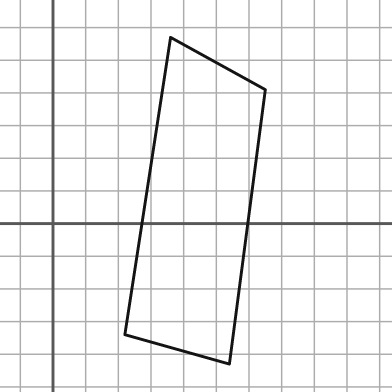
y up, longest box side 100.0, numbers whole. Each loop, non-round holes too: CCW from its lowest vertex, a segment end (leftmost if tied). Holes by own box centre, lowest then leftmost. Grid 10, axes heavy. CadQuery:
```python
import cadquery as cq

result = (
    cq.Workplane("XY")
    .moveTo(54.0, -43.0)
    .lineTo(65.0, 41.0)
    .lineTo(36.0, 57.0)
    .lineTo(22.0, -34.0)
    .close()
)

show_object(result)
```